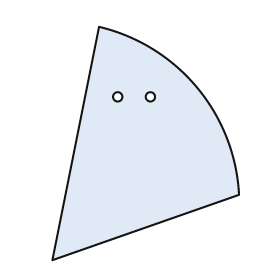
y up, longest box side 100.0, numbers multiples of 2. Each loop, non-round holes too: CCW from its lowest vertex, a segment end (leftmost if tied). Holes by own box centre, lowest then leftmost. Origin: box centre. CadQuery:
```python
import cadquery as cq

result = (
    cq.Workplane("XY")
    .moveTo(-40.0, -50.0)
    .lineTo(40.0, -22.0)
    .threePointArc((22.0, 24.0), (-20.0, 50.0))
    .close()
    .moveTo(-12.0, 20.0)
    .circle(2.0)
    .moveTo(2.0, 20.0)
    .circle(2.0)
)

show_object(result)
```